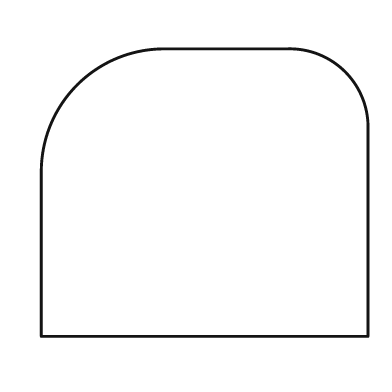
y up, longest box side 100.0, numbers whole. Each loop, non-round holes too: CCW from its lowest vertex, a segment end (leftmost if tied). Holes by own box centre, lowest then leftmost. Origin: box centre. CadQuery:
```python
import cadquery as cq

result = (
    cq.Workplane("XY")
    .moveTo(-50.0, -44.0)
    .lineTo(50.0, -44.0)
    .lineTo(50.0, 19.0)
    .threePointArc((43.0, 37.0), (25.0, 44.0))
    .lineTo(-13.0, 44.0)
    .threePointArc((-39.0, 33.0), (-50.0, 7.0))
    .close()
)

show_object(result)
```